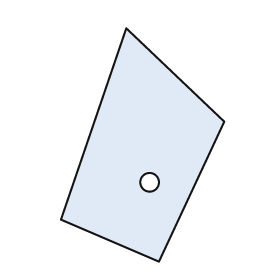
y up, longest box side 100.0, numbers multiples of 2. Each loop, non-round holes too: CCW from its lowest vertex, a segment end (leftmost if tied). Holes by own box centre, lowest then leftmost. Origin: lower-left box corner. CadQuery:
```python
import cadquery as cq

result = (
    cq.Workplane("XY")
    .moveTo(42.0, 0.0)
    .lineTo(70.0, 60.0)
    .lineTo(28.0, 100.0)
    .lineTo(0.0, 18.0)
    .close()
    .moveTo(38.0, 34.0)
    .circle(4.0)
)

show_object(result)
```